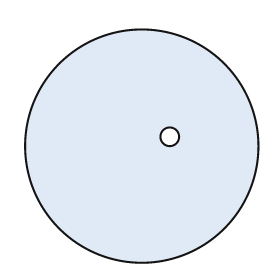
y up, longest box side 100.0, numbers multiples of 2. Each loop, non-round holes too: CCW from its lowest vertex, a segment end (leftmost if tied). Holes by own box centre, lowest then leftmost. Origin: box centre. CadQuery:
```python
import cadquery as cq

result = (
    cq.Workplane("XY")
    .moveTo(0.0, 0.0)
    .circle(50.0)
    .moveTo(12.0, 4.0)
    .circle(4.0)
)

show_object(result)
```